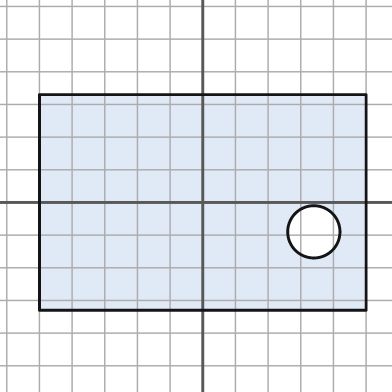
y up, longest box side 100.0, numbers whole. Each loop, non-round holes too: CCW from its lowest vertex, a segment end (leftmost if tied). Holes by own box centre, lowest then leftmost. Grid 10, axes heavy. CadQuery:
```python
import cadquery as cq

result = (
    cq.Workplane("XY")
    .moveTo(-50.0, -33.0)
    .lineTo(50.0, -33.0)
    .lineTo(50.0, 33.0)
    .lineTo(-50.0, 33.0)
    .close()
    .moveTo(34.0, -9.0)
    .circle(8.0)
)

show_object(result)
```